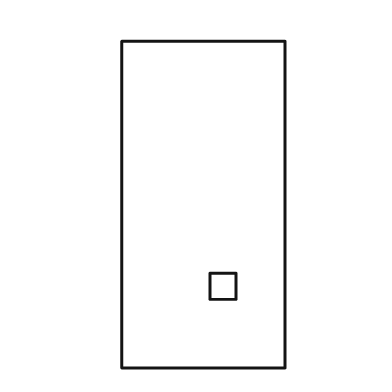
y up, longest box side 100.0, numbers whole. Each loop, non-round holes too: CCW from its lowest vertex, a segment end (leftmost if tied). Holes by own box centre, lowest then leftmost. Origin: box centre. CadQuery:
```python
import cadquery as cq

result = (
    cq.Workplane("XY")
    .moveTo(-25.0, -50.0)
    .lineTo(25.0, -50.0)
    .lineTo(25.0, 50.0)
    .lineTo(-25.0, 50.0)
    .close()
    .moveTo(2.0, -29.0)
    .lineTo(10.0, -29.0)
    .lineTo(10.0, -21.0)
    .lineTo(2.0, -21.0)
    .close()
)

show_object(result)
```